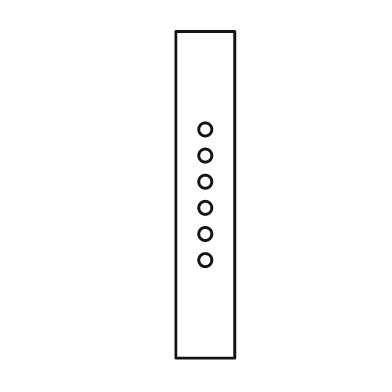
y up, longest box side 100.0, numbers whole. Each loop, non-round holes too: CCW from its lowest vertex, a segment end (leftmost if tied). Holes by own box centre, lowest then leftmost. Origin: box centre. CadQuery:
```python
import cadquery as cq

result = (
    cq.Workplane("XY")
    .moveTo(-9.0, -50.0)
    .lineTo(9.0, -50.0)
    .lineTo(9.0, 50.0)
    .lineTo(-9.0, 50.0)
    .close()
    .moveTo(0.0, -20.0)
    .circle(2.0)
    .moveTo(0.0, -12.0)
    .circle(2.0)
    .moveTo(0.0, -4.0)
    .circle(2.0)
    .moveTo(0.0, 4.0)
    .circle(2.0)
    .moveTo(0.0, 12.0)
    .circle(2.0)
    .moveTo(0.0, 20.0)
    .circle(2.0)
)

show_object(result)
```